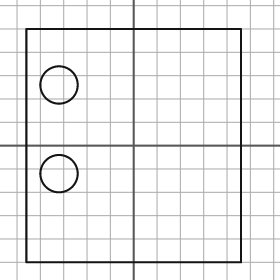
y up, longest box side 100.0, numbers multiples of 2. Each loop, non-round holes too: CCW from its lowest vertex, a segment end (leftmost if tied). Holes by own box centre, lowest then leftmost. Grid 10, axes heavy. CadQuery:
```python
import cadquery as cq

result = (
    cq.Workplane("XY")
    .moveTo(-46.0, -50.0)
    .lineTo(46.0, -50.0)
    .lineTo(46.0, 50.0)
    .lineTo(-46.0, 50.0)
    .close()
    .moveTo(-32.0, -12.0)
    .circle(8.0)
    .moveTo(-32.0, 26.0)
    .circle(8.0)
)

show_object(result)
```